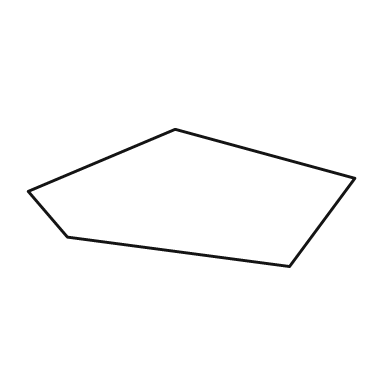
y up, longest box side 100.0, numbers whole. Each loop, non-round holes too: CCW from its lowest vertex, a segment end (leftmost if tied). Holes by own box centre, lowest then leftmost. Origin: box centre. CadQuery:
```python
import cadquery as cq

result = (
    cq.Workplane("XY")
    .moveTo(30.0, -21.0)
    .lineTo(50.0, 6.0)
    .lineTo(-5.0, 21.0)
    .lineTo(-50.0, 2.0)
    .lineTo(-38.0, -12.0)
    .close()
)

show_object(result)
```